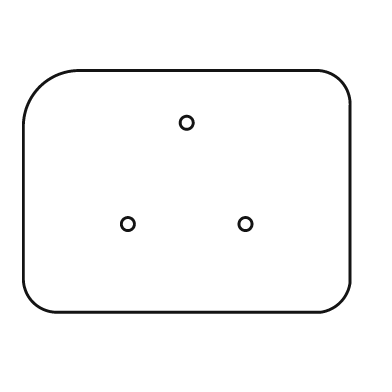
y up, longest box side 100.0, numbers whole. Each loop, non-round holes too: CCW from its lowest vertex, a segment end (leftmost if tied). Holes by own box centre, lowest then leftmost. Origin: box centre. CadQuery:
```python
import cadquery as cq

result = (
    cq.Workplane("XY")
    .moveTo(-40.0, -37.0)
    .lineTo(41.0, -37.0)
    .threePointArc((47.0, -34.0), (50.0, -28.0))
    .lineTo(50.0, 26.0)
    .threePointArc((47.0, 34.0), (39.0, 37.0))
    .lineTo(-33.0, 37.0)
    .threePointArc((-45.0, 32.0), (-50.0, 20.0))
    .lineTo(-50.0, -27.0)
    .threePointArc((-47.0, -34.0), (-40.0, -37.0))
    .close()
    .moveTo(-18.0, -10.0)
    .circle(2.0)
    .moveTo(18.0, -10.0)
    .circle(2.0)
    .moveTo(0.0, 21.0)
    .circle(2.0)
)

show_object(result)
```